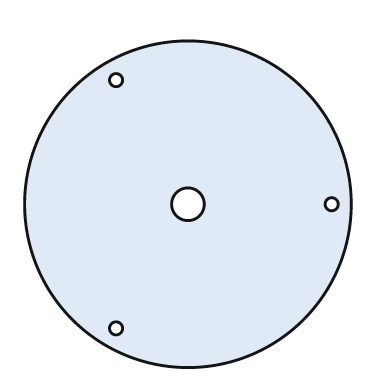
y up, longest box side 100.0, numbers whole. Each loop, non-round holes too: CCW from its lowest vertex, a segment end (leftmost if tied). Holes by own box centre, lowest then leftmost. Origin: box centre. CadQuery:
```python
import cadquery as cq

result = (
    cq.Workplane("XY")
    .moveTo(0.0, 0.0)
    .circle(50.0)
    .moveTo(-22.0, -38.0)
    .circle(2.0)
    .moveTo(0.0, 0.0)
    .circle(5.0)
    .moveTo(44.0, 0.0)
    .circle(2.0)
    .moveTo(-22.0, 38.0)
    .circle(2.0)
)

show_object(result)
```